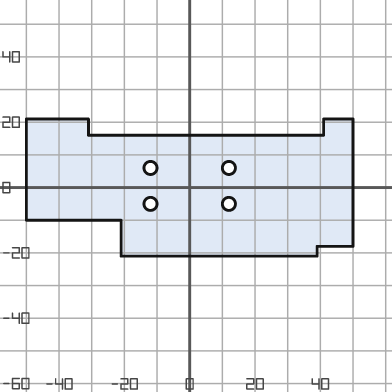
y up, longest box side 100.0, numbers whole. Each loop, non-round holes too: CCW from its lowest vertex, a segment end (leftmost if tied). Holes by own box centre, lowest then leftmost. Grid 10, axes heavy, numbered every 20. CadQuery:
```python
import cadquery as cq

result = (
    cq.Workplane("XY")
    .moveTo(-21.0, -21.0)
    .lineTo(39.0, -21.0)
    .lineTo(39.0, -18.0)
    .lineTo(50.0, -18.0)
    .lineTo(50.0, 21.0)
    .lineTo(41.0, 21.0)
    .lineTo(41.0, 16.0)
    .lineTo(-31.0, 16.0)
    .lineTo(-31.0, 21.0)
    .lineTo(-50.0, 21.0)
    .lineTo(-50.0, -10.0)
    .lineTo(-21.0, -10.0)
    .close()
    .moveTo(-12.0, -5.0)
    .circle(2.0)
    .moveTo(12.0, -5.0)
    .circle(2.0)
    .moveTo(-12.0, 6.0)
    .circle(2.0)
    .moveTo(12.0, 6.0)
    .circle(2.0)
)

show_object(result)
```